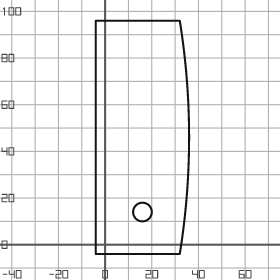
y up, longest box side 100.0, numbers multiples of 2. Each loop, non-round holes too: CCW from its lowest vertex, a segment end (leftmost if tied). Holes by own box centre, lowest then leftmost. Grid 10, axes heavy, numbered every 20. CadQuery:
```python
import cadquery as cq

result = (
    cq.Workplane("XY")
    .moveTo(-4.0, -4.0)
    .lineTo(32.0, -4.0)
    .threePointArc((36.0, 46.0), (32.0, 96.0))
    .lineTo(-4.0, 96.0)
    .close()
    .moveTo(16.0, 14.0)
    .circle(4.0)
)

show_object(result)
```